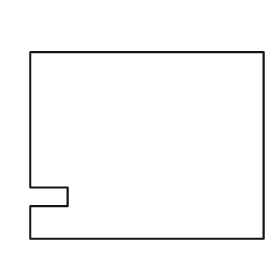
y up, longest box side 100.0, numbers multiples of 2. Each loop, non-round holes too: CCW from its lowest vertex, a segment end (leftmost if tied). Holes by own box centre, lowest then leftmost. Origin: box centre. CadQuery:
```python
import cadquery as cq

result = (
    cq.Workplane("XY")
    .moveTo(-50.0, -40.0)
    .lineTo(50.0, -40.0)
    .lineTo(50.0, 40.0)
    .lineTo(-50.0, 40.0)
    .lineTo(-50.0, -18.0)
    .lineTo(-34.0, -18.0)
    .lineTo(-34.0, -26.0)
    .lineTo(-50.0, -26.0)
    .close()
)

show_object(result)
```